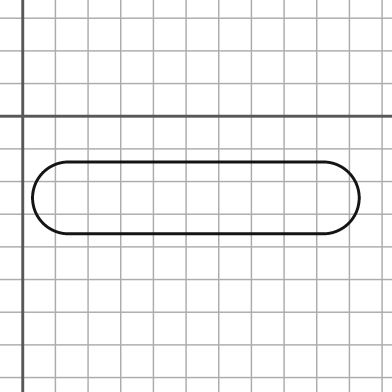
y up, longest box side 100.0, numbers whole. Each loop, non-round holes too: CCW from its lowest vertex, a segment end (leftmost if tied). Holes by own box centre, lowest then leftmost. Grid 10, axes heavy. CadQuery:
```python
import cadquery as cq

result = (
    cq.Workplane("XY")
    .moveTo(14.0, -36.0)
    .lineTo(92.0, -36.0)
    .threePointArc((103.0, -25.0), (92.0, -14.0))
    .lineTo(14.0, -14.0)
    .threePointArc((3.0, -25.0), (14.0, -36.0))
    .close()
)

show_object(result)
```